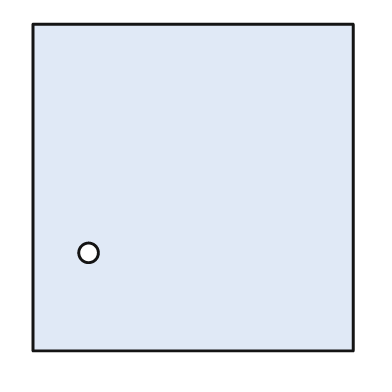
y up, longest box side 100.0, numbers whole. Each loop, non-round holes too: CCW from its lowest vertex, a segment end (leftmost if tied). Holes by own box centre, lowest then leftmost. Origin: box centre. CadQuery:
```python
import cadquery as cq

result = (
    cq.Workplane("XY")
    .moveTo(-49.0, -50.0)
    .lineTo(49.0, -50.0)
    .lineTo(49.0, 50.0)
    .lineTo(-49.0, 50.0)
    .close()
    .moveTo(-32.0, -20.0)
    .circle(3.0)
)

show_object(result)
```